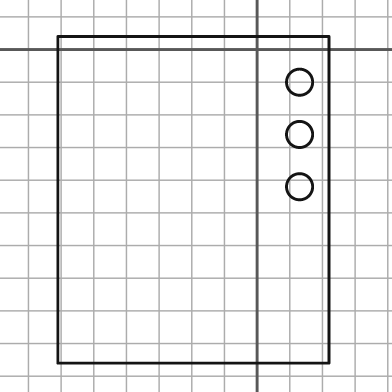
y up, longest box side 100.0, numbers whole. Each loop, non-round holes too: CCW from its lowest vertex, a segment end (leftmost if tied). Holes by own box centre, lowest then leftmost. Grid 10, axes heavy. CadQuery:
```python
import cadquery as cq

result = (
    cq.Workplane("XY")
    .moveTo(-61.0, -96.0)
    .lineTo(22.0, -96.0)
    .lineTo(22.0, 4.0)
    .lineTo(-61.0, 4.0)
    .close()
    .moveTo(13.0, -42.0)
    .circle(4.0)
    .moveTo(13.0, -26.0)
    .circle(4.0)
    .moveTo(13.0, -10.0)
    .circle(4.0)
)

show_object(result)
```